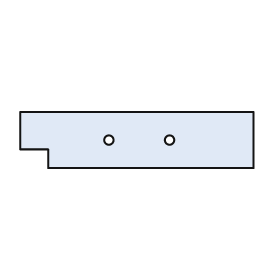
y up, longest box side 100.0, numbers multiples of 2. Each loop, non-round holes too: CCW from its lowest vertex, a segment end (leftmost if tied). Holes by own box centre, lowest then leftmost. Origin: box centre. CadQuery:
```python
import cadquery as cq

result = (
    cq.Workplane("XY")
    .moveTo(-38.0, -12.0)
    .lineTo(50.0, -12.0)
    .lineTo(50.0, 12.0)
    .lineTo(-50.0, 12.0)
    .lineTo(-50.0, -4.0)
    .lineTo(-38.0, -4.0)
    .close()
    .moveTo(-12.0, 0.0)
    .circle(2.0)
    .moveTo(14.0, 0.0)
    .circle(2.0)
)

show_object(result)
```